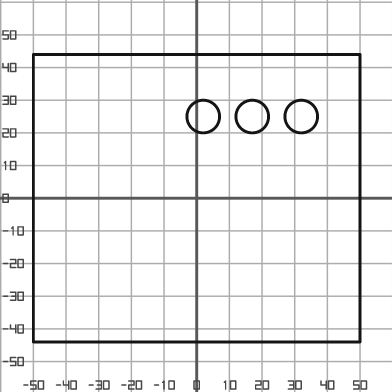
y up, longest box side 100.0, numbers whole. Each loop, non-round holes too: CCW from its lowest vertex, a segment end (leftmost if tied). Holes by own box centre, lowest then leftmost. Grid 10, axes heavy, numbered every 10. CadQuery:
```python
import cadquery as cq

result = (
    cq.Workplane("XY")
    .moveTo(-50.0, -44.0)
    .lineTo(50.0, -44.0)
    .lineTo(50.0, 44.0)
    .lineTo(-50.0, 44.0)
    .close()
    .moveTo(2.0, 25.0)
    .circle(5.0)
    .moveTo(17.0, 25.0)
    .circle(5.0)
    .moveTo(32.0, 25.0)
    .circle(5.0)
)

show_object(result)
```